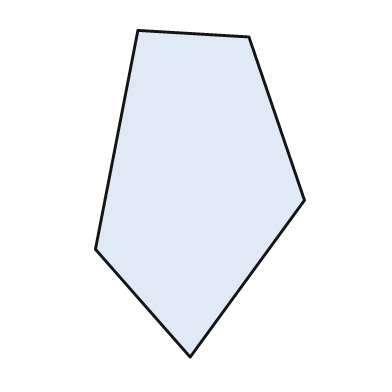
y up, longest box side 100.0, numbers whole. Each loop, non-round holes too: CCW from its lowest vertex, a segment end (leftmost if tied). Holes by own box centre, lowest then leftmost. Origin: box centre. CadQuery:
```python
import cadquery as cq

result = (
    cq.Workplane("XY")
    .moveTo(-3.0, -50.0)
    .lineTo(32.0, -2.0)
    .lineTo(15.0, 48.0)
    .lineTo(-19.0, 50.0)
    .lineTo(-32.0, -17.0)
    .close()
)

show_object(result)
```